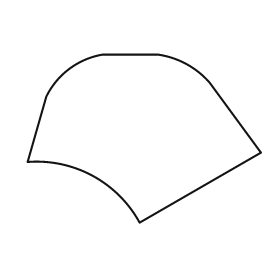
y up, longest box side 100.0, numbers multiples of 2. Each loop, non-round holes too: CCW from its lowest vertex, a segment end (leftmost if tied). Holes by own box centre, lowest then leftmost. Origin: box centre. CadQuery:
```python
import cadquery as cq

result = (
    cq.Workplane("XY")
    .moveTo(-2.0, -36.0)
    .lineTo(50.0, -6.0)
    .lineTo(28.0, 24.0)
    .threePointArc((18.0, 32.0), (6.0, 36.0))
    .lineTo(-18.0, 36.0)
    .threePointArc((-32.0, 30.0), (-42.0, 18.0))
    .lineTo(-50.0, -10.0)
    .threePointArc((-22.0, -16.0), (-2.0, -36.0))
    .close()
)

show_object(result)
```